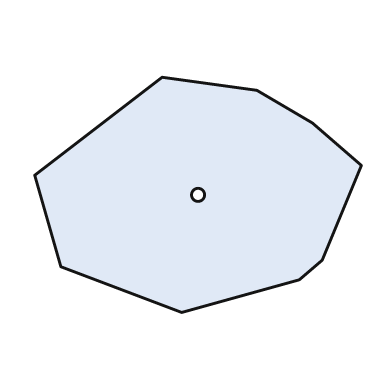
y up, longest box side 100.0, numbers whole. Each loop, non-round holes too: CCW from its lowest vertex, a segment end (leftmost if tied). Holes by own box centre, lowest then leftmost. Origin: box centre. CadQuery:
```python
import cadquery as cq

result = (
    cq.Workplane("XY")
    .moveTo(-5.0, -36.0)
    .lineTo(31.0, -26.0)
    .lineTo(38.0, -20.0)
    .lineTo(50.0, 9.0)
    .lineTo(35.0, 22.0)
    .lineTo(18.0, 32.0)
    .lineTo(-11.0, 36.0)
    .lineTo(-50.0, 6.0)
    .lineTo(-42.0, -22.0)
    .close()
    .moveTo(0.0, 0.0)
    .circle(2.0)
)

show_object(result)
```